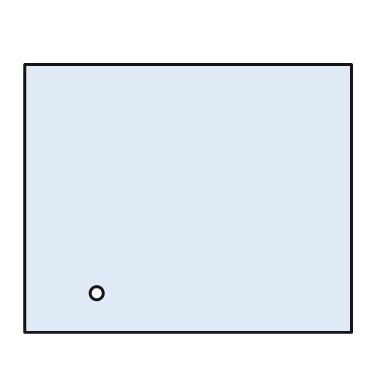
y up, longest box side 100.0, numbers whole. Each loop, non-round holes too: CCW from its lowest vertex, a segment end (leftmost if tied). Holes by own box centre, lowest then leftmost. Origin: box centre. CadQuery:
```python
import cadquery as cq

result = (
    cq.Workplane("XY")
    .moveTo(-50.0, -41.0)
    .lineTo(50.0, -41.0)
    .lineTo(50.0, 41.0)
    .lineTo(-50.0, 41.0)
    .close()
    .moveTo(-28.0, -29.0)
    .circle(2.0)
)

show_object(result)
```